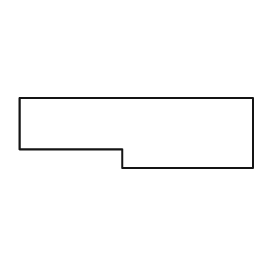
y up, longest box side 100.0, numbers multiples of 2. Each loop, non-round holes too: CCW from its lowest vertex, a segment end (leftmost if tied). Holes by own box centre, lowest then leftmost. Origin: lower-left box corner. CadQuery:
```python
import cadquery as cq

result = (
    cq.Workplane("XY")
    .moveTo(44.0, 0.0)
    .lineTo(100.0, 0.0)
    .lineTo(100.0, 30.0)
    .lineTo(0.0, 30.0)
    .lineTo(0.0, 8.0)
    .lineTo(44.0, 8.0)
    .close()
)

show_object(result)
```